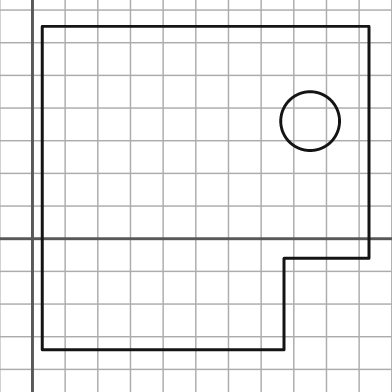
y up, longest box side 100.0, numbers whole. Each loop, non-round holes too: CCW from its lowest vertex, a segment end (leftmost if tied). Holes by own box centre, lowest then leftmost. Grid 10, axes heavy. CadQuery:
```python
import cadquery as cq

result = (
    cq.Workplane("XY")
    .moveTo(3.0, -34.0)
    .lineTo(77.0, -34.0)
    .lineTo(77.0, -6.0)
    .lineTo(103.0, -6.0)
    .lineTo(103.0, 65.0)
    .lineTo(3.0, 65.0)
    .close()
    .moveTo(85.0, 36.0)
    .circle(9.0)
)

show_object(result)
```